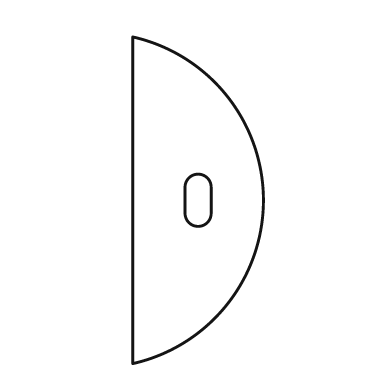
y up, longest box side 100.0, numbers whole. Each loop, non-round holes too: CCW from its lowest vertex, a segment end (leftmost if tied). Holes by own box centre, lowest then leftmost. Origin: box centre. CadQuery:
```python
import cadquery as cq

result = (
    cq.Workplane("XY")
    .moveTo(-20.0, -50.0)
    .threePointArc((20.0, 0.0), (-20.0, 50.0))
    .close()
    .moveTo(-4.0, -4.0)
    .threePointArc((0.0, -8.0), (4.0, -4.0))
    .lineTo(4.0, 4.0)
    .threePointArc((0.0, 8.0), (-4.0, 4.0))
    .close()
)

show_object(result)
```